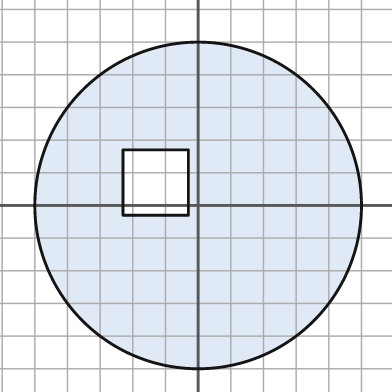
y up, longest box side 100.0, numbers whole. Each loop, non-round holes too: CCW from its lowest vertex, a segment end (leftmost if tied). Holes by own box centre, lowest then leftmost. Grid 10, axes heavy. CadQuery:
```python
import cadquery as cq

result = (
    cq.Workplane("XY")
    .moveTo(0.0, 0.0)
    .circle(50.0)
    .moveTo(-23.0, -3.0)
    .lineTo(-3.0, -3.0)
    .lineTo(-3.0, 17.0)
    .lineTo(-23.0, 17.0)
    .close()
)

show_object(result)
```